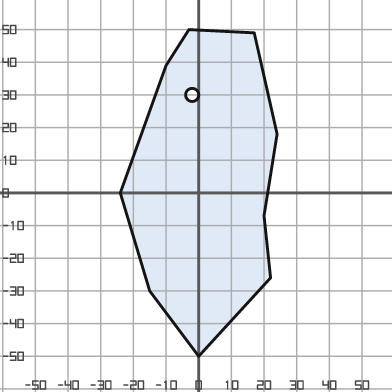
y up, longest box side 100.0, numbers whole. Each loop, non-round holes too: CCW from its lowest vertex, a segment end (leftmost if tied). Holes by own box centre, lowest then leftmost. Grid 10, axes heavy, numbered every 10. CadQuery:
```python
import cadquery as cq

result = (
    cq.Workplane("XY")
    .moveTo(0.0, -50.0)
    .lineTo(22.0, -26.0)
    .lineTo(20.0, -7.0)
    .lineTo(24.0, 18.0)
    .lineTo(17.0, 49.0)
    .lineTo(-3.0, 50.0)
    .lineTo(-10.0, 39.0)
    .lineTo(-24.0, 0.0)
    .lineTo(-15.0, -30.0)
    .close()
    .moveTo(-2.0, 30.0)
    .circle(2.0)
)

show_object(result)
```